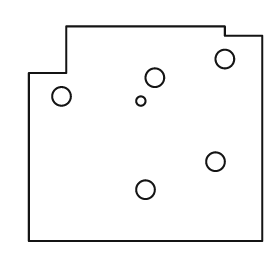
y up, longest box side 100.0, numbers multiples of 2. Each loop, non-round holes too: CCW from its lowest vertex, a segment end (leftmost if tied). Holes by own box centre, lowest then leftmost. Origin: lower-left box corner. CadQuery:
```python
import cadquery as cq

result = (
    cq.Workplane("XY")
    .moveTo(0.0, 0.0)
    .lineTo(100.0, 0.0)
    .lineTo(100.0, 88.0)
    .lineTo(84.0, 88.0)
    .lineTo(84.0, 92.0)
    .lineTo(16.0, 92.0)
    .lineTo(16.0, 72.0)
    .lineTo(0.0, 72.0)
    .close()
    .moveTo(50.0, 22.0)
    .circle(4.0)
    .moveTo(80.0, 34.0)
    .circle(4.0)
    .moveTo(48.0, 60.0)
    .circle(2.0)
    .moveTo(14.0, 62.0)
    .circle(4.0)
    .moveTo(54.0, 70.0)
    .circle(4.0)
    .moveTo(84.0, 78.0)
    .circle(4.0)
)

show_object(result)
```